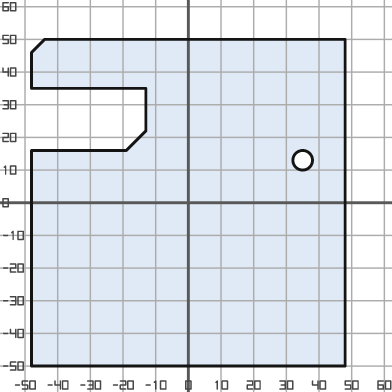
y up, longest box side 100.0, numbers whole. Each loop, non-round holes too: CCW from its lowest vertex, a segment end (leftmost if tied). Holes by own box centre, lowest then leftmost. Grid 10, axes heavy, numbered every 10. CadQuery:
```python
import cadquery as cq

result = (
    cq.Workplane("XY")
    .moveTo(-48.0, -50.0)
    .lineTo(48.0, -50.0)
    .lineTo(48.0, 50.0)
    .lineTo(-44.0, 50.0)
    .lineTo(-48.0, 46.0)
    .lineTo(-48.0, 35.0)
    .lineTo(-13.0, 35.0)
    .lineTo(-13.0, 22.0)
    .lineTo(-19.0, 16.0)
    .lineTo(-48.0, 16.0)
    .close()
    .moveTo(35.0, 13.0)
    .circle(3.0)
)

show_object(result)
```